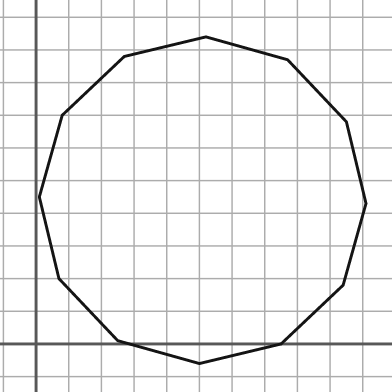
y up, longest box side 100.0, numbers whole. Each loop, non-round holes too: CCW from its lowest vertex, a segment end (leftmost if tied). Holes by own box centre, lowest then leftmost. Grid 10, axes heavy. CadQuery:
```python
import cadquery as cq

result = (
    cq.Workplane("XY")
    .moveTo(50.0, -6.0)
    .lineTo(75.0, 0.0)
    .lineTo(94.0, 18.0)
    .lineTo(101.0, 43.0)
    .lineTo(95.0, 68.0)
    .lineTo(77.0, 87.0)
    .lineTo(52.0, 94.0)
    .lineTo(27.0, 88.0)
    .lineTo(8.0, 70.0)
    .lineTo(1.0, 45.0)
    .lineTo(7.0, 20.0)
    .lineTo(25.0, 1.0)
    .close()
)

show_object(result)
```